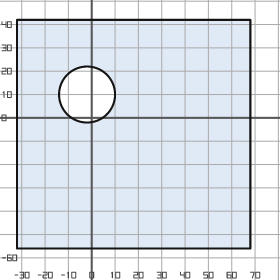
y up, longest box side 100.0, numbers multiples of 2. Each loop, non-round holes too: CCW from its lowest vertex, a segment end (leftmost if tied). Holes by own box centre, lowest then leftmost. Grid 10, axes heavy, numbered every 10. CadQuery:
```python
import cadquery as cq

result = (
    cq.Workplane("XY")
    .moveTo(-32.0, -56.0)
    .lineTo(68.0, -56.0)
    .lineTo(68.0, 42.0)
    .lineTo(-32.0, 42.0)
    .close()
    .moveTo(-2.0, 10.0)
    .circle(12.0)
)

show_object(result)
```